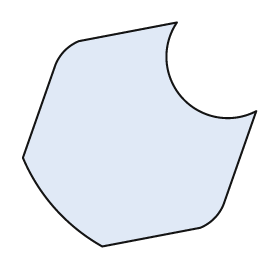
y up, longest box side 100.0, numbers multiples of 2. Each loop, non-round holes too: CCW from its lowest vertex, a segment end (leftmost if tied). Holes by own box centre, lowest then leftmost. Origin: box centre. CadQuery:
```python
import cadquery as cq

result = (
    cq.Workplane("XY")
    .moveTo(-16.0, -48.0)
    .lineTo(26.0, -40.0)
    .threePointArc((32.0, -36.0), (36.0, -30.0))
    .lineTo(50.0, 10.0)
    .threePointArc((18.0, 16.0), (16.0, 48.0))
    .lineTo(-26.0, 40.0)
    .threePointArc((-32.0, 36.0), (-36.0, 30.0))
    .lineTo(-50.0, -10.0)
    .threePointArc((-36.0, -32.0), (-16.0, -48.0))
    .close()
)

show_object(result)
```